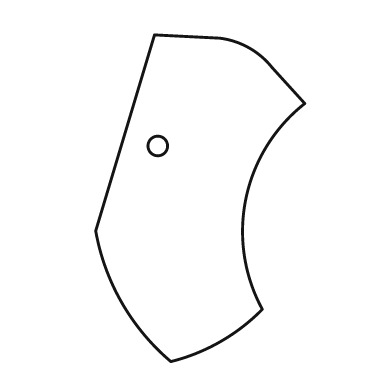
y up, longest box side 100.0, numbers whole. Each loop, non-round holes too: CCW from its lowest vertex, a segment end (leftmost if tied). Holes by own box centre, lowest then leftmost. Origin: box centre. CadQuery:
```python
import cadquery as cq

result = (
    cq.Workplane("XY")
    .moveTo(-9.0, -50.0)
    .threePointArc((6.0, -44.0), (19.0, -34.0))
    .threePointArc((14.0, 0.0), (32.0, 29.0))
    .lineTo(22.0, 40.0)
    .threePointArc((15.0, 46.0), (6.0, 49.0))
    .lineTo(-14.0, 50.0)
    .lineTo(-32.0, -10.0)
    .threePointArc((-24.0, -32.0), (-9.0, -50.0))
    .close()
    .moveTo(-13.0, 16.0)
    .circle(3.0)
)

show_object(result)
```